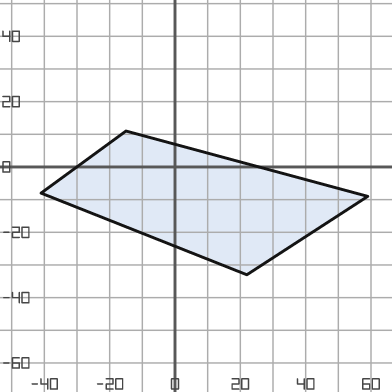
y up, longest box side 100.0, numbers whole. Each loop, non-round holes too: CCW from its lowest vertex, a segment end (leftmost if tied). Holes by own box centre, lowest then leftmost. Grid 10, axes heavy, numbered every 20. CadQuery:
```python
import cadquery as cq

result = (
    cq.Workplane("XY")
    .moveTo(22.0, -33.0)
    .lineTo(59.0, -9.0)
    .lineTo(-15.0, 11.0)
    .lineTo(-41.0, -8.0)
    .close()
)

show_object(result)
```